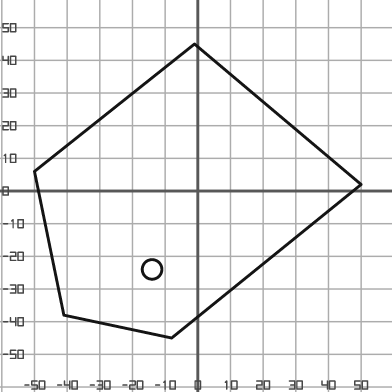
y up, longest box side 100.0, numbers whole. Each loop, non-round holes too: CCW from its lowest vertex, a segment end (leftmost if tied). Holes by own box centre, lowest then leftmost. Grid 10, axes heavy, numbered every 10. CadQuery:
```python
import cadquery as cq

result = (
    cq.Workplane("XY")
    .moveTo(-8.0, -45.0)
    .lineTo(50.0, 2.0)
    .lineTo(-1.0, 45.0)
    .lineTo(-50.0, 6.0)
    .lineTo(-41.0, -38.0)
    .close()
    .moveTo(-14.0, -24.0)
    .circle(3.0)
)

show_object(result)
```